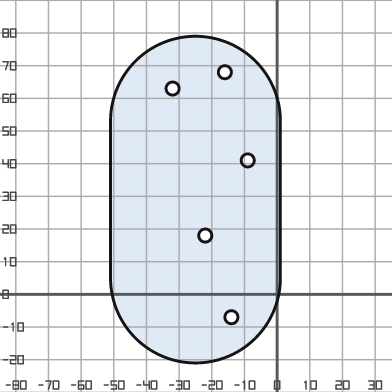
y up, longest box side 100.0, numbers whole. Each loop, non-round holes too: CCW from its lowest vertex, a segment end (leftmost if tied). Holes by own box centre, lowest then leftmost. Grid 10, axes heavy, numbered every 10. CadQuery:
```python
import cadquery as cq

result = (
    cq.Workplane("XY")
    .moveTo(-51.0, 5.0)
    .threePointArc((-25.0, -21.0), (1.0, 5.0))
    .lineTo(1.0, 53.0)
    .threePointArc((-25.0, 79.0), (-51.0, 53.0))
    .close()
    .moveTo(-14.0, -7.0)
    .circle(2.0)
    .moveTo(-22.0, 18.0)
    .circle(2.0)
    .moveTo(-9.0, 41.0)
    .circle(2.0)
    .moveTo(-32.0, 63.0)
    .circle(2.0)
    .moveTo(-16.0, 68.0)
    .circle(2.0)
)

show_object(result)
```